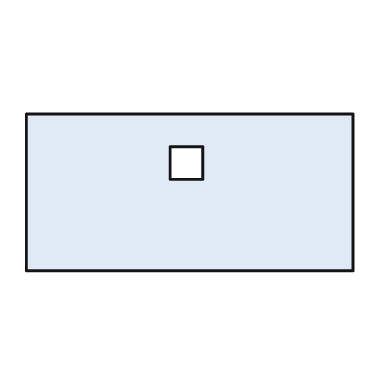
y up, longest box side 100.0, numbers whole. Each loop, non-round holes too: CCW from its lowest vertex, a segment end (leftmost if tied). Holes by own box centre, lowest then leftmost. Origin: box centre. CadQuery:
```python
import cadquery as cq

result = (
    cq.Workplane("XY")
    .moveTo(-50.0, -24.0)
    .lineTo(50.0, -24.0)
    .lineTo(50.0, 24.0)
    .lineTo(-50.0, 24.0)
    .close()
    .moveTo(-6.0, 4.0)
    .lineTo(4.0, 4.0)
    .lineTo(4.0, 14.0)
    .lineTo(-6.0, 14.0)
    .close()
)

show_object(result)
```